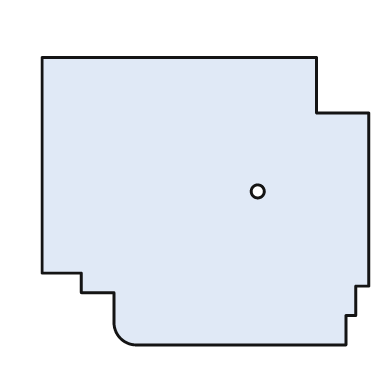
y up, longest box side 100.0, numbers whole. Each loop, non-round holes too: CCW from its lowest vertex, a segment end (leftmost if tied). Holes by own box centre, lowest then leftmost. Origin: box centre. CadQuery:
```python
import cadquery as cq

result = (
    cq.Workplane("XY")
    .moveTo(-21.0, -44.0)
    .lineTo(43.0, -44.0)
    .lineTo(43.0, -35.0)
    .lineTo(46.0, -35.0)
    .lineTo(46.0, -26.0)
    .lineTo(50.0, -26.0)
    .lineTo(50.0, 27.0)
    .lineTo(34.0, 27.0)
    .lineTo(34.0, 44.0)
    .lineTo(-50.0, 44.0)
    .lineTo(-50.0, -22.0)
    .lineTo(-38.0, -22.0)
    .lineTo(-38.0, -28.0)
    .lineTo(-28.0, -28.0)
    .lineTo(-28.0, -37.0)
    .threePointArc((-26.0, -42.0), (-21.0, -44.0))
    .close()
    .moveTo(16.0, 3.0)
    .circle(2.0)
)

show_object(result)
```